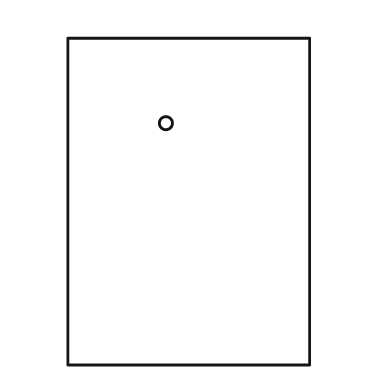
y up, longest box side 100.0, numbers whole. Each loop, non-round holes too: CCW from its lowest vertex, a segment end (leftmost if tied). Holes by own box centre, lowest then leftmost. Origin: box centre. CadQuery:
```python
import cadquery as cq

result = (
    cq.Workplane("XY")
    .moveTo(-37.0, -50.0)
    .lineTo(37.0, -50.0)
    .lineTo(37.0, 50.0)
    .lineTo(-37.0, 50.0)
    .close()
    .moveTo(-7.0, 24.0)
    .circle(2.0)
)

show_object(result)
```